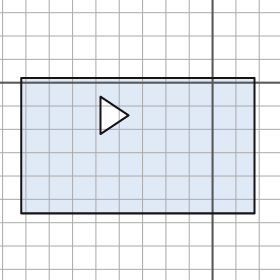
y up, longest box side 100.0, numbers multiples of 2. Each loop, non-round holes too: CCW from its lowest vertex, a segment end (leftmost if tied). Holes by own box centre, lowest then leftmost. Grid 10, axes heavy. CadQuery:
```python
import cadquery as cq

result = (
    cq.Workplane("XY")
    .moveTo(-82.0, -56.0)
    .lineTo(18.0, -56.0)
    .lineTo(18.0, 2.0)
    .lineTo(-82.0, 2.0)
    .close()
    .moveTo(-48.0, -22.0)
    .lineTo(-36.0, -14.0)
    .lineTo(-48.0, -6.0)
    .close()
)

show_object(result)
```